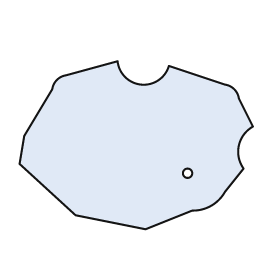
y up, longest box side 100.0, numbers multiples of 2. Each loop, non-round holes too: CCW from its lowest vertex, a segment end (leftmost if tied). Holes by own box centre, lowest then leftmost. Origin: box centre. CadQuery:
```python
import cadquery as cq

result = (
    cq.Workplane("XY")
    .moveTo(4.0, -36.0)
    .lineTo(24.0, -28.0)
    .threePointArc((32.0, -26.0), (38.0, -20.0))
    .lineTo(46.0, -10.0)
    .threePointArc((44.0, 0.0), (50.0, 8.0))
    .lineTo(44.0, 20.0)
    .threePointArc((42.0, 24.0), (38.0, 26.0))
    .lineTo(14.0, 34.0)
    .threePointArc((2.0, 26.0), (-8.0, 36.0))
    .lineTo(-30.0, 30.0)
    .threePointArc((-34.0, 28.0), (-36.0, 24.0))
    .lineTo(-48.0, 4.0)
    .lineTo(-50.0, -8.0)
    .lineTo(-26.0, -30.0)
    .close()
    .moveTo(22.0, -12.0)
    .circle(2.0)
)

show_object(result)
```